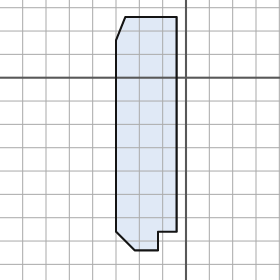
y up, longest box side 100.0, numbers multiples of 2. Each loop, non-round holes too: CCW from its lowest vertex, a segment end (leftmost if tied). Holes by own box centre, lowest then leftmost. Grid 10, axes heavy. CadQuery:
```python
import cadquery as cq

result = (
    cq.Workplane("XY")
    .moveTo(-22.0, -74.0)
    .lineTo(-12.0, -74.0)
    .lineTo(-12.0, -66.0)
    .lineTo(-4.0, -66.0)
    .lineTo(-4.0, 26.0)
    .lineTo(-26.0, 26.0)
    .lineTo(-30.0, 16.0)
    .lineTo(-30.0, -66.0)
    .close()
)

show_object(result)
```